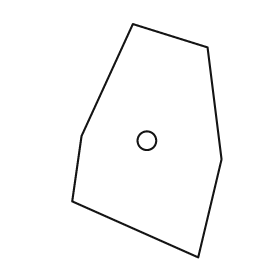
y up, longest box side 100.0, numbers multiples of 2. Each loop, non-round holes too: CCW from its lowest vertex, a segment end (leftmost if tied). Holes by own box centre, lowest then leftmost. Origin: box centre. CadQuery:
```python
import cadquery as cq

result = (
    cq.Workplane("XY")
    .moveTo(22.0, -50.0)
    .lineTo(32.0, -8.0)
    .lineTo(26.0, 40.0)
    .lineTo(-6.0, 50.0)
    .lineTo(-28.0, 2.0)
    .lineTo(-32.0, -26.0)
    .close()
    .moveTo(0.0, 0.0)
    .circle(4.0)
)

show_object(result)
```